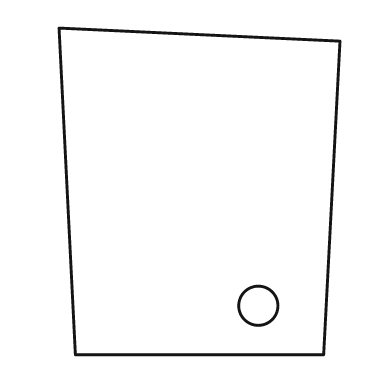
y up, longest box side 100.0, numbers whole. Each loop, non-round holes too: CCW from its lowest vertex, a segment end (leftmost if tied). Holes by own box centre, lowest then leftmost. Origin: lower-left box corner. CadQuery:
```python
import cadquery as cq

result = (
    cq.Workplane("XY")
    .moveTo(5.0, 0.0)
    .lineTo(81.0, 0.0)
    .lineTo(86.0, 96.0)
    .lineTo(0.0, 100.0)
    .close()
    .moveTo(61.0, 15.0)
    .circle(6.0)
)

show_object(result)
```